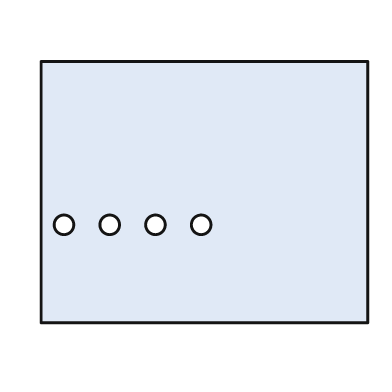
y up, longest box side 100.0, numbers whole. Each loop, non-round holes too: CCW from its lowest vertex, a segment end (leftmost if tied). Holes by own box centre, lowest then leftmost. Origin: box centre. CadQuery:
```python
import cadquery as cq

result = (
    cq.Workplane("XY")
    .moveTo(-50.0, -40.0)
    .lineTo(50.0, -40.0)
    .lineTo(50.0, 40.0)
    .lineTo(-50.0, 40.0)
    .close()
    .moveTo(-43.0, -10.0)
    .circle(3.0)
    .moveTo(-29.0, -10.0)
    .circle(3.0)
    .moveTo(-15.0, -10.0)
    .circle(3.0)
    .moveTo(-1.0, -10.0)
    .circle(3.0)
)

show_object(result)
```